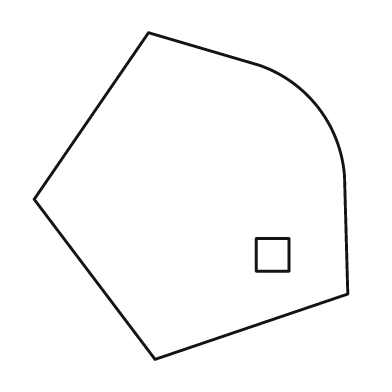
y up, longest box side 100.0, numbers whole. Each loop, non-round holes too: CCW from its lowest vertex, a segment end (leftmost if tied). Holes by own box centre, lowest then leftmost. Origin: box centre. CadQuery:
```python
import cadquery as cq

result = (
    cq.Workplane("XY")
    .moveTo(-11.0, -50.0)
    .lineTo(48.0, -30.0)
    .lineTo(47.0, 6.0)
    .threePointArc((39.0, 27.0), (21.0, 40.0))
    .lineTo(-13.0, 50.0)
    .lineTo(-48.0, -1.0)
    .close()
    .moveTo(20.0, -23.0)
    .lineTo(30.0, -23.0)
    .lineTo(30.0, -13.0)
    .lineTo(20.0, -13.0)
    .close()
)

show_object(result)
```